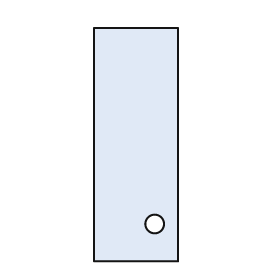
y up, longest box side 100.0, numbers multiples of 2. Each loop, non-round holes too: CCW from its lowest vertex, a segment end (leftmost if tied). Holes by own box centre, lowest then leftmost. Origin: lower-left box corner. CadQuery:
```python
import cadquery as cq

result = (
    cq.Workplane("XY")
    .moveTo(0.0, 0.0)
    .lineTo(36.0, 0.0)
    .lineTo(36.0, 100.0)
    .lineTo(0.0, 100.0)
    .close()
    .moveTo(26.0, 16.0)
    .circle(4.0)
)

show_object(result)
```